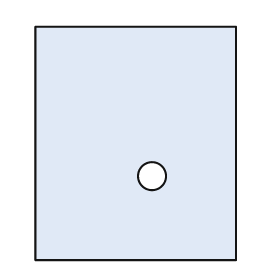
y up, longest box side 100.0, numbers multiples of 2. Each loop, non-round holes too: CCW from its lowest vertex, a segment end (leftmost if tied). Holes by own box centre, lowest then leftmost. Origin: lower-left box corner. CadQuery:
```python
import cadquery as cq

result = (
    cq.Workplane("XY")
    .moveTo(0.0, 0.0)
    .lineTo(86.0, 0.0)
    .lineTo(86.0, 100.0)
    .lineTo(0.0, 100.0)
    .close()
    .moveTo(50.0, 36.0)
    .circle(6.0)
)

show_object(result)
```